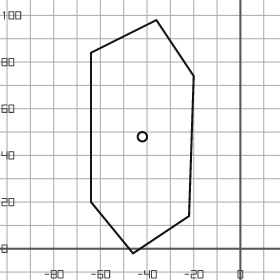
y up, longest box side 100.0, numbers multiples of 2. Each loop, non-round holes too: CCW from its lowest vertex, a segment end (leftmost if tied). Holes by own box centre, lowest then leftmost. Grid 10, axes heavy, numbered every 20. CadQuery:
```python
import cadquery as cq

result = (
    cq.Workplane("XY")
    .moveTo(-46.0, -2.0)
    .lineTo(-22.0, 14.0)
    .lineTo(-20.0, 74.0)
    .lineTo(-36.0, 98.0)
    .lineTo(-64.0, 84.0)
    .lineTo(-64.0, 20.0)
    .close()
    .moveTo(-42.0, 48.0)
    .circle(2.0)
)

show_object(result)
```